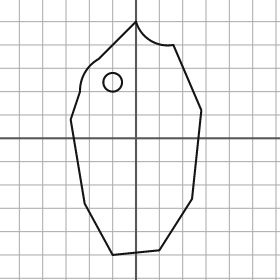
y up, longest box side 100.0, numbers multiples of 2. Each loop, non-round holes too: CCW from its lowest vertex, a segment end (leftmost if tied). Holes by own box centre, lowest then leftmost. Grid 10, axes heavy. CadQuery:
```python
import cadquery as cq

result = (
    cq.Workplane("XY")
    .moveTo(-10.0, -50.0)
    .lineTo(10.0, -48.0)
    .lineTo(24.0, -26.0)
    .lineTo(28.0, 12.0)
    .lineTo(16.0, 40.0)
    .threePointArc((6.0, 42.0), (0.0, 50.0))
    .lineTo(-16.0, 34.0)
    .threePointArc((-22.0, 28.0), (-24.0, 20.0))
    .lineTo(-28.0, 8.0)
    .lineTo(-22.0, -28.0)
    .close()
    .moveTo(-10.0, 24.0)
    .circle(4.0)
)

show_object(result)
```